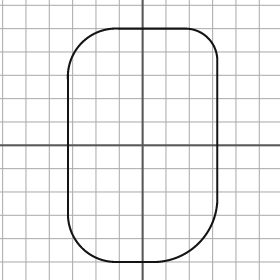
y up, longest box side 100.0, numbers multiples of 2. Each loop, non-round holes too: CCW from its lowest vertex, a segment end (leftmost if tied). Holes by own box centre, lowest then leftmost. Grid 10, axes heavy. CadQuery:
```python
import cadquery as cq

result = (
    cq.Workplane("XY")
    .moveTo(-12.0, -50.0)
    .lineTo(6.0, -50.0)
    .threePointArc((24.0, -42.0), (32.0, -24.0))
    .lineTo(32.0, 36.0)
    .threePointArc((28.0, 46.0), (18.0, 50.0))
    .lineTo(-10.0, 50.0)
    .threePointArc((-26.0, 44.0), (-32.0, 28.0))
    .lineTo(-32.0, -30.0)
    .threePointArc((-26.0, -44.0), (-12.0, -50.0))
    .close()
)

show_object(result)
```